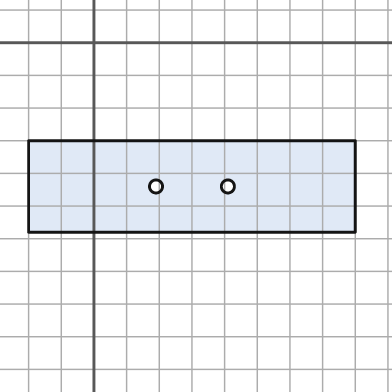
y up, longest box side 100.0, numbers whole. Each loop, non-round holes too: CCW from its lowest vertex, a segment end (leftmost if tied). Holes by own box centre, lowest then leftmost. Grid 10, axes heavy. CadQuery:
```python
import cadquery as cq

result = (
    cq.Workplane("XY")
    .moveTo(-20.0, -58.0)
    .lineTo(80.0, -58.0)
    .lineTo(80.0, -30.0)
    .lineTo(-20.0, -30.0)
    .close()
    .moveTo(19.0, -44.0)
    .circle(2.0)
    .moveTo(41.0, -44.0)
    .circle(2.0)
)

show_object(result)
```